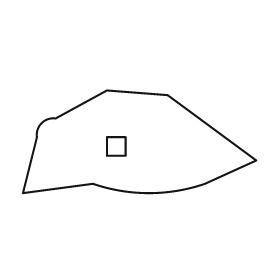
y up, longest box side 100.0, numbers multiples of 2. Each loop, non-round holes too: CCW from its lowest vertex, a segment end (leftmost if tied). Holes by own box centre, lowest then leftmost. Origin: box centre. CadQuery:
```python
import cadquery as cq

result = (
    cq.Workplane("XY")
    .moveTo(-50.0, -22.0)
    .lineTo(-20.0, -18.0)
    .threePointArc((4.0, -22.0), (28.0, -18.0))
    .lineTo(50.0, -8.0)
    .lineTo(12.0, 20.0)
    .lineTo(-14.0, 22.0)
    .lineTo(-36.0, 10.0)
    .threePointArc((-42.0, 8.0), (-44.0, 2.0))
    .close()
    .moveTo(-14.0, -6.0)
    .lineTo(-6.0, -6.0)
    .lineTo(-6.0, 2.0)
    .lineTo(-14.0, 2.0)
    .close()
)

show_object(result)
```